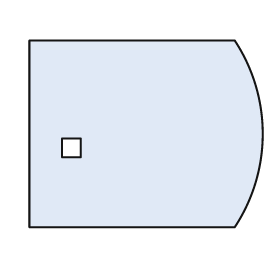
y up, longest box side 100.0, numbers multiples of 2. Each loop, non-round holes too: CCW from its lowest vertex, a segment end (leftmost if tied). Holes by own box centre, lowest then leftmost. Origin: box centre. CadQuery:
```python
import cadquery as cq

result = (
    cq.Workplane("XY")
    .moveTo(-50.0, -40.0)
    .lineTo(38.0, -40.0)
    .threePointArc((50.0, 0.0), (38.0, 40.0))
    .lineTo(-50.0, 40.0)
    .close()
    .moveTo(-36.0, -10.0)
    .lineTo(-28.0, -10.0)
    .lineTo(-28.0, -2.0)
    .lineTo(-36.0, -2.0)
    .close()
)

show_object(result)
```